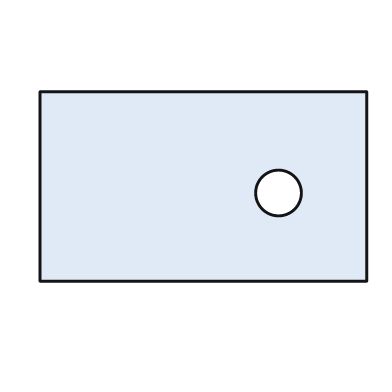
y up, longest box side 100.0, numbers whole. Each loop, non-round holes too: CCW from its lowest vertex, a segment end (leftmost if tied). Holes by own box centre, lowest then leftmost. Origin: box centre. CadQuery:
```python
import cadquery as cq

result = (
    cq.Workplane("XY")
    .moveTo(-50.0, -29.0)
    .lineTo(50.0, -29.0)
    .lineTo(50.0, 29.0)
    .lineTo(-50.0, 29.0)
    .close()
    .moveTo(23.0, -2.0)
    .circle(7.0)
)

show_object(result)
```